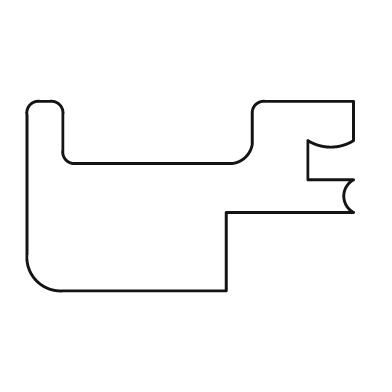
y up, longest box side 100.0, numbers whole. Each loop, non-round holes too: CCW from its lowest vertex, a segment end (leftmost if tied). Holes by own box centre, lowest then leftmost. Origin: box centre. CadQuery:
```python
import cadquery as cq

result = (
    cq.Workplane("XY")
    .moveTo(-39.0, -29.0)
    .lineTo(11.0, -29.0)
    .lineTo(11.0, -5.0)
    .lineTo(50.0, -5.0)
    .threePointArc((47.0, 0.0), (50.0, 5.0))
    .lineTo(36.0, 5.0)
    .lineTo(36.0, 17.0)
    .threePointArc((43.0, 15.0), (50.0, 17.0))
    .lineTo(50.0, 29.0)
    .lineTo(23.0, 29.0)
    .threePointArc((20.0, 28.0), (19.0, 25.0))
    .lineTo(19.0, 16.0)
    .threePointArc((17.0, 12.0), (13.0, 10.0))
    .lineTo(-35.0, 10.0)
    .threePointArc((-38.0, 11.0), (-39.0, 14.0))
    .lineTo(-39.0, 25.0)
    .threePointArc((-40.0, 28.0), (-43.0, 29.0))
    .lineTo(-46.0, 29.0)
    .threePointArc((-49.0, 28.0), (-50.0, 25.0))
    .lineTo(-50.0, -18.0)
    .threePointArc((-47.0, -26.0), (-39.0, -29.0))
    .close()
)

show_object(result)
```